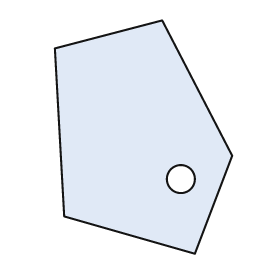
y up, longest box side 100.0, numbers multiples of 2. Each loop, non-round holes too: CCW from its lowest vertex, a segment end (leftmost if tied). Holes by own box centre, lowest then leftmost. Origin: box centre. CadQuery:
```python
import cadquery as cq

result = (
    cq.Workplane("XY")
    .moveTo(22.0, -50.0)
    .lineTo(38.0, -8.0)
    .lineTo(8.0, 50.0)
    .lineTo(-38.0, 38.0)
    .lineTo(-34.0, -34.0)
    .close()
    .moveTo(16.0, -18.0)
    .circle(6.0)
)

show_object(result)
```